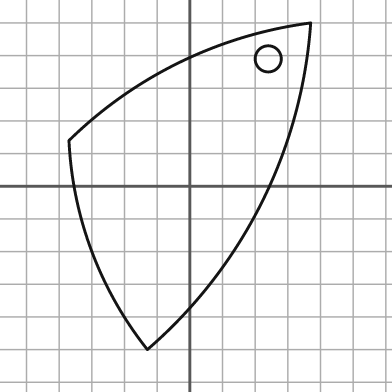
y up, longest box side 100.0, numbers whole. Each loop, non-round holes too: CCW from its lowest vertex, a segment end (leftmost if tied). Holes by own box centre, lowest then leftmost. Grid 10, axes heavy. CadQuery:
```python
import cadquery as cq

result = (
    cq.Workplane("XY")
    .moveTo(-13.0, -50.0)
    .threePointArc((22.0, -5.0), (37.0, 50.0))
    .threePointArc((-3.0, 38.0), (-37.0, 14.0))
    .threePointArc((-30.0, -20.0), (-13.0, -50.0))
    .close()
    .moveTo(24.0, 39.0)
    .circle(4.0)
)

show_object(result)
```